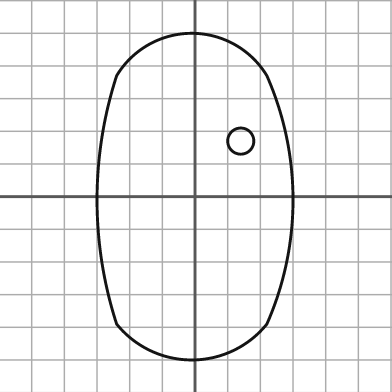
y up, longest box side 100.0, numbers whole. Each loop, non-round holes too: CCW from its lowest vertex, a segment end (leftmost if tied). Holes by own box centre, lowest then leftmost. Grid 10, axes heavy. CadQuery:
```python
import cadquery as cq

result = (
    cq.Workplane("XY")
    .moveTo(-24.0, -39.0)
    .threePointArc((-1.0, -50.0), (22.0, -39.0))
    .threePointArc((30.0, -1.0), (22.0, 37.0))
    .threePointArc((-1.0, 50.0), (-24.0, 37.0))
    .threePointArc((-30.0, -1.0), (-24.0, -39.0))
    .close()
    .moveTo(14.0, 17.0)
    .circle(4.0)
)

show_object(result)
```